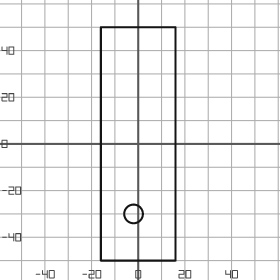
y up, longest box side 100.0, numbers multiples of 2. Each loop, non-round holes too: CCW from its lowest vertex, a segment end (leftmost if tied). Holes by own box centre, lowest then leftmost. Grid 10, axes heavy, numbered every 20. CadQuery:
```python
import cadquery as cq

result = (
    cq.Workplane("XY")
    .moveTo(-16.0, -50.0)
    .lineTo(16.0, -50.0)
    .lineTo(16.0, 50.0)
    .lineTo(-16.0, 50.0)
    .close()
    .moveTo(-2.0, -30.0)
    .circle(4.0)
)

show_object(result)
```